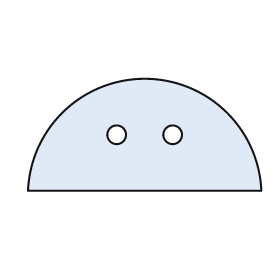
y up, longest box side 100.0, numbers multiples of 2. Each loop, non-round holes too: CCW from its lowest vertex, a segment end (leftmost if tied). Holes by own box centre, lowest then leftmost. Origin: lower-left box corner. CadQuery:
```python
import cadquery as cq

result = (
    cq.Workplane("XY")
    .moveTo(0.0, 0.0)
    .lineTo(100.0, 0.0)
    .threePointArc((50.0, 48.0), (0.0, 0.0))
    .close()
    .moveTo(38.0, 24.0)
    .circle(4.0)
    .moveTo(62.0, 24.0)
    .circle(4.0)
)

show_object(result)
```